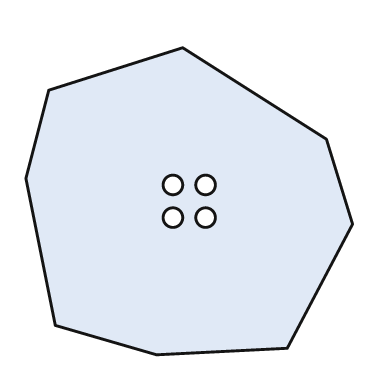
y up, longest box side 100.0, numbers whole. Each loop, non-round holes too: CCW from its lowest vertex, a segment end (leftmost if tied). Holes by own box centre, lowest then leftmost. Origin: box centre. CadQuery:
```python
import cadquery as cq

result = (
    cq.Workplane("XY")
    .moveTo(-10.0, -47.0)
    .lineTo(30.0, -45.0)
    .lineTo(50.0, -7.0)
    .lineTo(42.0, 19.0)
    .lineTo(-2.0, 47.0)
    .lineTo(-43.0, 34.0)
    .lineTo(-50.0, 7.0)
    .lineTo(-41.0, -38.0)
    .close()
    .moveTo(-5.0, -5.0)
    .circle(3.0)
    .moveTo(5.0, -5.0)
    .circle(3.0)
    .moveTo(-5.0, 5.0)
    .circle(3.0)
    .moveTo(5.0, 5.0)
    .circle(3.0)
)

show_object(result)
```